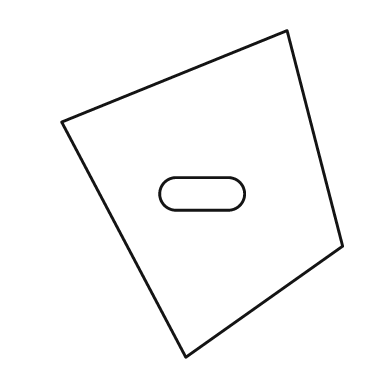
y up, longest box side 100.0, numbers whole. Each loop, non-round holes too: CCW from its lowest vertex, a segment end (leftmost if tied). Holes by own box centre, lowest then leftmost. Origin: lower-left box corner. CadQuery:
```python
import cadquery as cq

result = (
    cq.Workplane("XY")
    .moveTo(38.0, 0.0)
    .lineTo(86.0, 34.0)
    .lineTo(69.0, 100.0)
    .lineTo(0.0, 72.0)
    .close()
    .moveTo(35.0, 45.0)
    .lineTo(51.0, 45.0)
    .threePointArc((56.0, 50.0), (51.0, 55.0))
    .lineTo(35.0, 55.0)
    .threePointArc((30.0, 50.0), (35.0, 45.0))
    .close()
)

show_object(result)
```